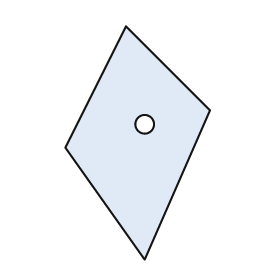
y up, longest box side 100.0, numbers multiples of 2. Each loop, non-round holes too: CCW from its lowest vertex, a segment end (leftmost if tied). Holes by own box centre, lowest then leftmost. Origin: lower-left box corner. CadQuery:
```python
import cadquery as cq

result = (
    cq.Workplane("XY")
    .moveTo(34.0, 0.0)
    .lineTo(62.0, 64.0)
    .lineTo(26.0, 100.0)
    .lineTo(0.0, 48.0)
    .close()
    .moveTo(34.0, 58.0)
    .circle(4.0)
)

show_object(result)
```